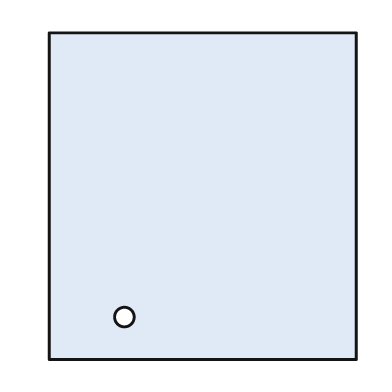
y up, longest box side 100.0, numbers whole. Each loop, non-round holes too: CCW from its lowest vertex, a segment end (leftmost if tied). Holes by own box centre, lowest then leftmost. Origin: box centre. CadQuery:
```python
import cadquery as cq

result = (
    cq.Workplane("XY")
    .moveTo(-47.0, -50.0)
    .lineTo(47.0, -50.0)
    .lineTo(47.0, 50.0)
    .lineTo(-47.0, 50.0)
    .close()
    .moveTo(-24.0, -37.0)
    .circle(3.0)
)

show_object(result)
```